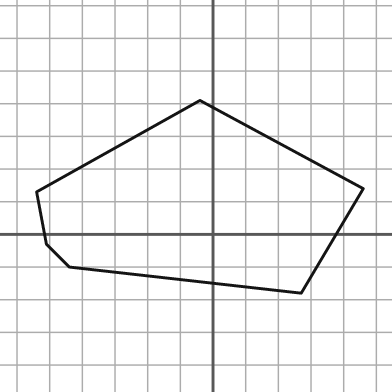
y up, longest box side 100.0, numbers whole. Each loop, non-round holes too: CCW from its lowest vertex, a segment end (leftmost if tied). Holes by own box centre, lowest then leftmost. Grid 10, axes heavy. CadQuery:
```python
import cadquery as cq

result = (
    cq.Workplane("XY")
    .moveTo(27.0, -18.0)
    .lineTo(46.0, 14.0)
    .lineTo(-4.0, 41.0)
    .lineTo(-54.0, 13.0)
    .lineTo(-51.0, -3.0)
    .lineTo(-44.0, -10.0)
    .close()
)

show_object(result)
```